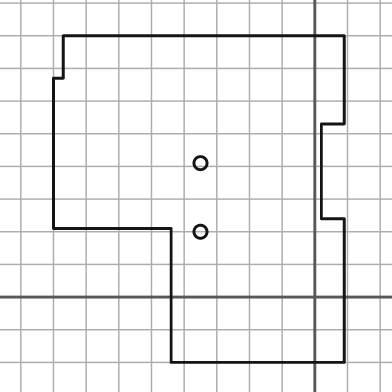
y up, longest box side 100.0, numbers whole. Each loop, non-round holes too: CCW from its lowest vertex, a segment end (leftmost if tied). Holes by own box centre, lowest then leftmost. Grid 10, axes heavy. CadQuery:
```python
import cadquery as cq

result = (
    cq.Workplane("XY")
    .moveTo(-44.0, -20.0)
    .lineTo(9.0, -20.0)
    .lineTo(9.0, 24.0)
    .lineTo(2.0, 24.0)
    .lineTo(2.0, 53.0)
    .lineTo(9.0, 53.0)
    .lineTo(9.0, 80.0)
    .lineTo(-77.0, 80.0)
    .lineTo(-77.0, 67.0)
    .lineTo(-80.0, 67.0)
    .lineTo(-80.0, 21.0)
    .lineTo(-44.0, 21.0)
    .close()
    .moveTo(-35.0, 20.0)
    .circle(2.0)
    .moveTo(-35.0, 41.0)
    .circle(2.0)
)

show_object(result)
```